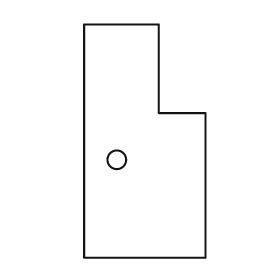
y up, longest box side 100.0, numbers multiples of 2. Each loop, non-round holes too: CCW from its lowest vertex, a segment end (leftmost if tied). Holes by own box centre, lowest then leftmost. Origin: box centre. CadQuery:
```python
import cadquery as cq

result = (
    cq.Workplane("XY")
    .moveTo(-26.0, -50.0)
    .lineTo(26.0, -50.0)
    .lineTo(26.0, 12.0)
    .lineTo(6.0, 12.0)
    .lineTo(6.0, 50.0)
    .lineTo(-26.0, 50.0)
    .close()
    .moveTo(-12.0, -8.0)
    .circle(4.0)
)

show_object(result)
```